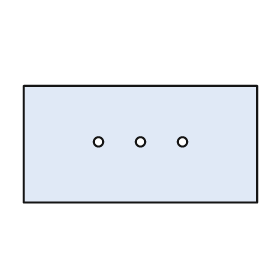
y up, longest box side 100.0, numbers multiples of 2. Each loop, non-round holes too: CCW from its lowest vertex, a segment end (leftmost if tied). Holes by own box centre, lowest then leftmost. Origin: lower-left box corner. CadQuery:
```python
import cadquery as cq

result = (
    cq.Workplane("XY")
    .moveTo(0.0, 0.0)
    .lineTo(100.0, 0.0)
    .lineTo(100.0, 50.0)
    .lineTo(0.0, 50.0)
    .close()
    .moveTo(32.0, 26.0)
    .circle(2.0)
    .moveTo(50.0, 26.0)
    .circle(2.0)
    .moveTo(68.0, 26.0)
    .circle(2.0)
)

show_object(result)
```